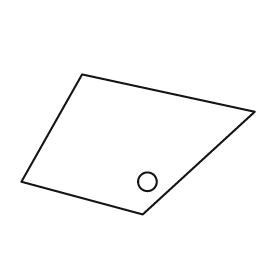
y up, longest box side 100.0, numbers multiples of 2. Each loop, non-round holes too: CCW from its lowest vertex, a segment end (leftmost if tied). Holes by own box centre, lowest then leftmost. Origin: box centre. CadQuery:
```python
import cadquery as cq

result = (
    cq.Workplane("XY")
    .moveTo(2.0, -30.0)
    .lineTo(50.0, 14.0)
    .lineTo(-24.0, 30.0)
    .lineTo(-50.0, -16.0)
    .close()
    .moveTo(4.0, -16.0)
    .circle(4.0)
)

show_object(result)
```